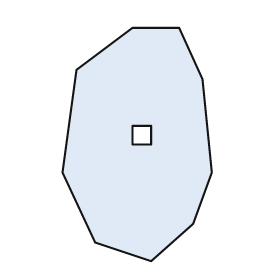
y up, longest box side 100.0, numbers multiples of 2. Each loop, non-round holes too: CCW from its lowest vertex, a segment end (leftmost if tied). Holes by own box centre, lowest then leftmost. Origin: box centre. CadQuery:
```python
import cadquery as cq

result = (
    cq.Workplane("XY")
    .moveTo(6.0, -50.0)
    .lineTo(24.0, -34.0)
    .lineTo(32.0, -12.0)
    .lineTo(28.0, 28.0)
    .lineTo(18.0, 50.0)
    .lineTo(-2.0, 50.0)
    .lineTo(-26.0, 32.0)
    .lineTo(-32.0, -12.0)
    .lineTo(-18.0, -42.0)
    .close()
    .moveTo(-2.0, 0.0)
    .lineTo(6.0, 0.0)
    .lineTo(6.0, 8.0)
    .lineTo(-2.0, 8.0)
    .close()
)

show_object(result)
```